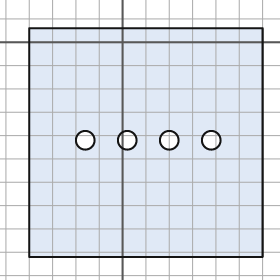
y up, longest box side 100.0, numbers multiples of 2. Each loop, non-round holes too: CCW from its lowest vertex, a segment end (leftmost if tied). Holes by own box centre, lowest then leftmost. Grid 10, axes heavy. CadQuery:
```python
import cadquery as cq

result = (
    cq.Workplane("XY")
    .moveTo(-40.0, -92.0)
    .lineTo(60.0, -92.0)
    .lineTo(60.0, 6.0)
    .lineTo(-40.0, 6.0)
    .close()
    .moveTo(-16.0, -42.0)
    .circle(4.0)
    .moveTo(2.0, -42.0)
    .circle(4.0)
    .moveTo(20.0, -42.0)
    .circle(4.0)
    .moveTo(38.0, -42.0)
    .circle(4.0)
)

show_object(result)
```